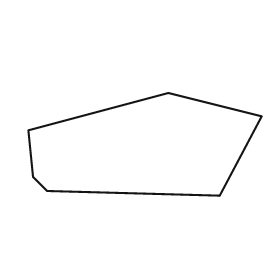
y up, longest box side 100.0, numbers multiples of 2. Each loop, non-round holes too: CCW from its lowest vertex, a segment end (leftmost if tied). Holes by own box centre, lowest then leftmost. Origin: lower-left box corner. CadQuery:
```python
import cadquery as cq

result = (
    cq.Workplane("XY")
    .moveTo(82.0, 0.0)
    .lineTo(100.0, 34.0)
    .lineTo(60.0, 44.0)
    .lineTo(0.0, 28.0)
    .lineTo(2.0, 8.0)
    .lineTo(8.0, 2.0)
    .close()
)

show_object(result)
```